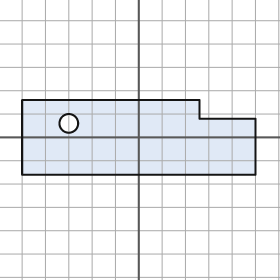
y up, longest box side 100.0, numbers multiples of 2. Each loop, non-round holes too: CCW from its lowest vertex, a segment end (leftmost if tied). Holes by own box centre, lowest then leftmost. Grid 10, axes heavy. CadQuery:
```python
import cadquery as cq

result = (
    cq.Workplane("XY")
    .moveTo(-50.0, -16.0)
    .lineTo(50.0, -16.0)
    .lineTo(50.0, 8.0)
    .lineTo(26.0, 8.0)
    .lineTo(26.0, 16.0)
    .lineTo(-50.0, 16.0)
    .close()
    .moveTo(-30.0, 6.0)
    .circle(4.0)
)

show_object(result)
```